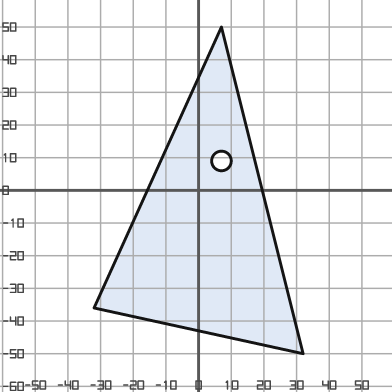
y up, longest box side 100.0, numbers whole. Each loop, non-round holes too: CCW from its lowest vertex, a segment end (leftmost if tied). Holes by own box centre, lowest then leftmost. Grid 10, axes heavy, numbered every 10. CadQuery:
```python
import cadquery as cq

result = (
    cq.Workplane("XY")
    .moveTo(32.0, -50.0)
    .lineTo(7.0, 50.0)
    .lineTo(-32.0, -36.0)
    .close()
    .moveTo(7.0, 9.0)
    .circle(3.0)
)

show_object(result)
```